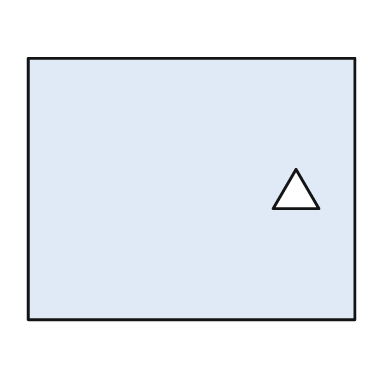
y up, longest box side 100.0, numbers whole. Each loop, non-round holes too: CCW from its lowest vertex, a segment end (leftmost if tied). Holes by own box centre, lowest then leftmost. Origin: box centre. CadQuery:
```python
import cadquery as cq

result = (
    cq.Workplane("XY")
    .moveTo(-50.0, -40.0)
    .lineTo(50.0, -40.0)
    .lineTo(50.0, 40.0)
    .lineTo(-50.0, 40.0)
    .close()
    .moveTo(25.0, -6.0)
    .lineTo(39.0, -6.0)
    .lineTo(32.0, 6.0)
    .close()
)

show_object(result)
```